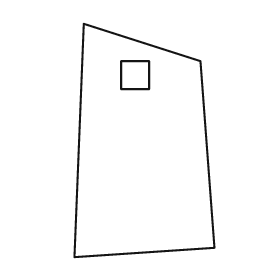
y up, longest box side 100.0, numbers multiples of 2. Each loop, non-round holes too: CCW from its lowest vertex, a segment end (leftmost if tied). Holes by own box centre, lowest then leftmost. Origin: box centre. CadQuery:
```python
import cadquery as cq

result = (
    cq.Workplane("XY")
    .moveTo(-30.0, -50.0)
    .lineTo(30.0, -46.0)
    .lineTo(24.0, 34.0)
    .lineTo(-26.0, 50.0)
    .close()
    .moveTo(-10.0, 22.0)
    .lineTo(2.0, 22.0)
    .lineTo(2.0, 34.0)
    .lineTo(-10.0, 34.0)
    .close()
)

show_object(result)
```